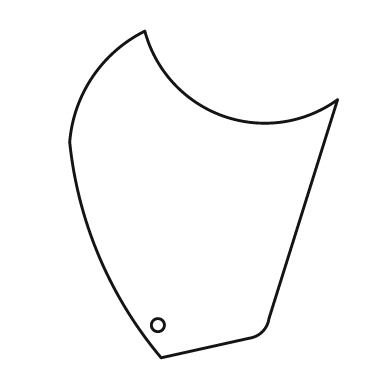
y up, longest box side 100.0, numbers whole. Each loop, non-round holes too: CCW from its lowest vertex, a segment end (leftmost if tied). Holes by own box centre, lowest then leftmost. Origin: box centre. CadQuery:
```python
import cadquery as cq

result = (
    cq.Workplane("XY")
    .moveTo(-13.0, -50.0)
    .lineTo(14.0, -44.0)
    .threePointArc((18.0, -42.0), (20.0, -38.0))
    .lineTo(41.0, 29.0)
    .threePointArc((6.0, 24.0), (-18.0, 50.0))
    .threePointArc((-34.0, 36.0), (-41.0, 16.0))
    .threePointArc((-32.0, -19.0), (-13.0, -50.0))
    .close()
    .moveTo(-14.0, -40.0)
    .circle(2.0)
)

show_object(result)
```